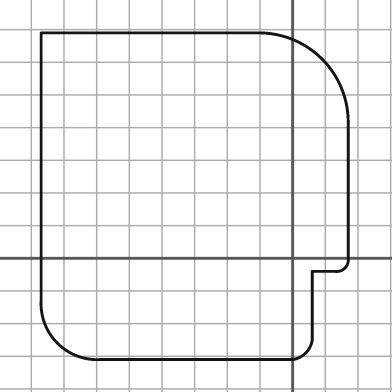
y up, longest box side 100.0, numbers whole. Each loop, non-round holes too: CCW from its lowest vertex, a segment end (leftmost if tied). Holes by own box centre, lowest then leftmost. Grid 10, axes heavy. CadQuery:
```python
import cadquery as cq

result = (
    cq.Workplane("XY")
    .moveTo(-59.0, -31.0)
    .lineTo(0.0, -31.0)
    .threePointArc((4.0, -29.0), (6.0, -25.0))
    .lineTo(6.0, -4.0)
    .lineTo(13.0, -4.0)
    .threePointArc((16.0, -3.0), (17.0, 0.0))
    .lineTo(17.0, 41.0)
    .threePointArc((9.0, 61.0), (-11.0, 69.0))
    .lineTo(-77.0, 69.0)
    .lineTo(-77.0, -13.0)
    .threePointArc((-72.0, -26.0), (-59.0, -31.0))
    .close()
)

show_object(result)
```